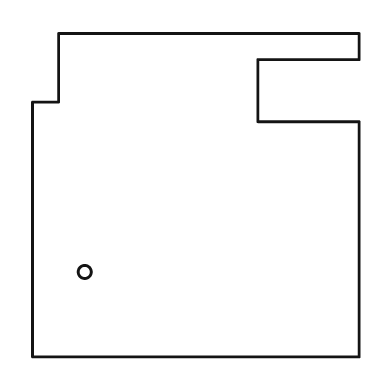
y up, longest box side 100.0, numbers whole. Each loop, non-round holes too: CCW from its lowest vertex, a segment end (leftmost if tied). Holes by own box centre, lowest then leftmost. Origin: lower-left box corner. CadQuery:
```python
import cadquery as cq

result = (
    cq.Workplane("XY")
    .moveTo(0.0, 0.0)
    .lineTo(100.0, 0.0)
    .lineTo(100.0, 72.0)
    .lineTo(69.0, 72.0)
    .lineTo(69.0, 91.0)
    .lineTo(100.0, 91.0)
    .lineTo(100.0, 99.0)
    .lineTo(8.0, 99.0)
    .lineTo(8.0, 78.0)
    .lineTo(0.0, 78.0)
    .close()
    .moveTo(16.0, 26.0)
    .circle(2.0)
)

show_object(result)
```